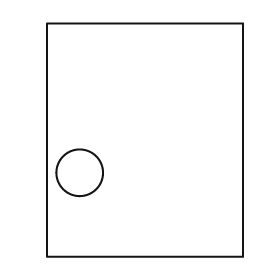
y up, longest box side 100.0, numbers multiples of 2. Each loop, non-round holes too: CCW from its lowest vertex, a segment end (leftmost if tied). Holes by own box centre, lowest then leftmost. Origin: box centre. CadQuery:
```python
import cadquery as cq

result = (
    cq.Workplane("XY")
    .moveTo(-42.0, -50.0)
    .lineTo(42.0, -50.0)
    .lineTo(42.0, 50.0)
    .lineTo(-42.0, 50.0)
    .close()
    .moveTo(-28.0, -14.0)
    .circle(10.0)
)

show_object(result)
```